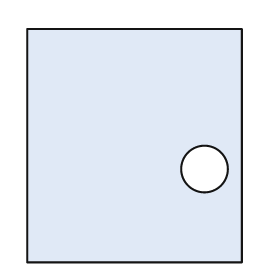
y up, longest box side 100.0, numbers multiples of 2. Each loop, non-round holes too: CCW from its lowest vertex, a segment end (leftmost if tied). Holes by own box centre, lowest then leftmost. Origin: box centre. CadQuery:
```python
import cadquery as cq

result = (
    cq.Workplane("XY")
    .moveTo(-46.0, -50.0)
    .lineTo(46.0, -50.0)
    .lineTo(46.0, 50.0)
    .lineTo(-46.0, 50.0)
    .close()
    .moveTo(30.0, -10.0)
    .circle(10.0)
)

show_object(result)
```